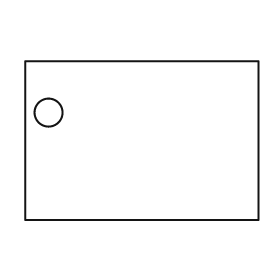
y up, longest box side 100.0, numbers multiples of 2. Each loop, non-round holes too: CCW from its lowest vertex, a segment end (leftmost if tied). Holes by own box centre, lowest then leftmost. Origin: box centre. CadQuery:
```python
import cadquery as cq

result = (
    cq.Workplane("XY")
    .moveTo(-50.0, -34.0)
    .lineTo(50.0, -34.0)
    .lineTo(50.0, 34.0)
    .lineTo(-50.0, 34.0)
    .close()
    .moveTo(-40.0, 12.0)
    .circle(6.0)
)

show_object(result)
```